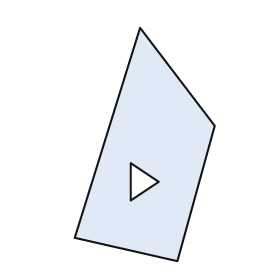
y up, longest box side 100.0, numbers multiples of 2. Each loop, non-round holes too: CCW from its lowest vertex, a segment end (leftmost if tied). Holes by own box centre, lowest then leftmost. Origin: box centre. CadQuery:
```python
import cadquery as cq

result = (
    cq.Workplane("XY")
    .moveTo(14.0, -50.0)
    .lineTo(30.0, 8.0)
    .lineTo(-2.0, 50.0)
    .lineTo(-30.0, -40.0)
    .close()
    .moveTo(-6.0, -24.0)
    .lineTo(6.0, -16.0)
    .lineTo(-6.0, -8.0)
    .close()
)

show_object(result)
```